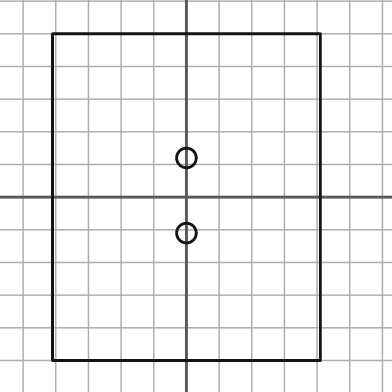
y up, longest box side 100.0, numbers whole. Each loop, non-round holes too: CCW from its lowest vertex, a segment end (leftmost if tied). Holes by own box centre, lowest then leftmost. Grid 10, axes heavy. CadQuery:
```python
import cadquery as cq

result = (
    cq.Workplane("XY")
    .moveTo(-41.0, -50.0)
    .lineTo(41.0, -50.0)
    .lineTo(41.0, 50.0)
    .lineTo(-41.0, 50.0)
    .close()
    .moveTo(0.0, -11.0)
    .circle(3.0)
    .moveTo(0.0, 12.0)
    .circle(3.0)
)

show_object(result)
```